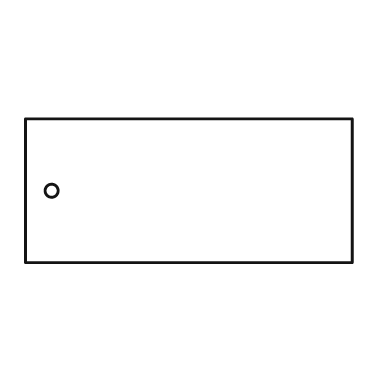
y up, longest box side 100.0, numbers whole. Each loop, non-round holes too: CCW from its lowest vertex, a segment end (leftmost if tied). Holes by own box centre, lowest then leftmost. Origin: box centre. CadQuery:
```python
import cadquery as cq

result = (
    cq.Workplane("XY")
    .moveTo(-50.0, -22.0)
    .lineTo(50.0, -22.0)
    .lineTo(50.0, 22.0)
    .lineTo(-50.0, 22.0)
    .close()
    .moveTo(-42.0, 0.0)
    .circle(2.0)
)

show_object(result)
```